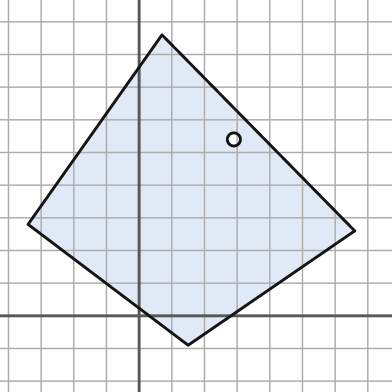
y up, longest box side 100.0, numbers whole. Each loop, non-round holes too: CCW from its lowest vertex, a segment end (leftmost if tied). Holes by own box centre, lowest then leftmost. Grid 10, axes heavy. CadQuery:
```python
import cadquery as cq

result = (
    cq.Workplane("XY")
    .moveTo(15.0, -9.0)
    .lineTo(66.0, 26.0)
    .lineTo(7.0, 86.0)
    .lineTo(-34.0, 28.0)
    .close()
    .moveTo(29.0, 54.0)
    .circle(2.0)
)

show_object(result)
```